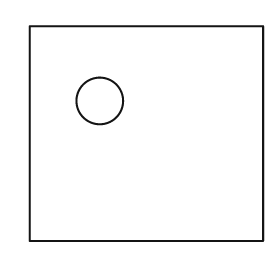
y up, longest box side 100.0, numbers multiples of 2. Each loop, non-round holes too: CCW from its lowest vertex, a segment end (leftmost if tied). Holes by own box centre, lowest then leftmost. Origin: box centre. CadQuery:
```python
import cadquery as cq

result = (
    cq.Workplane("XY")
    .moveTo(-50.0, -46.0)
    .lineTo(50.0, -46.0)
    .lineTo(50.0, 46.0)
    .lineTo(-50.0, 46.0)
    .close()
    .moveTo(-20.0, 14.0)
    .circle(10.0)
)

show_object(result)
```